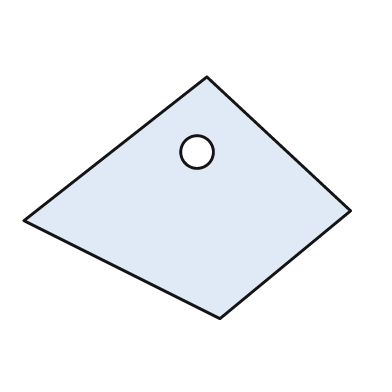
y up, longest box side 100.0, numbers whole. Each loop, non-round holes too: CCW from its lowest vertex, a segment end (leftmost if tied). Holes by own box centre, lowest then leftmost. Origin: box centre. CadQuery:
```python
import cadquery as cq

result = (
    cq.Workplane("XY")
    .moveTo(10.0, -37.0)
    .lineTo(50.0, -4.0)
    .lineTo(6.0, 37.0)
    .lineTo(-50.0, -7.0)
    .close()
    .moveTo(3.0, 14.0)
    .circle(5.0)
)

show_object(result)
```